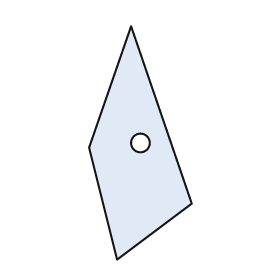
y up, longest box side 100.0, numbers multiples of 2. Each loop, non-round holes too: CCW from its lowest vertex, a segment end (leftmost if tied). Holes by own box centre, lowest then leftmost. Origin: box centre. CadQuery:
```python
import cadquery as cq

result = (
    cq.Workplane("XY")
    .moveTo(-10.0, -50.0)
    .lineTo(22.0, -26.0)
    .lineTo(-4.0, 50.0)
    .lineTo(-22.0, -2.0)
    .close()
    .moveTo(0.0, 0.0)
    .circle(4.0)
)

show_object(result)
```